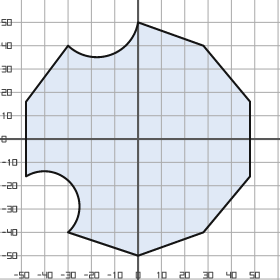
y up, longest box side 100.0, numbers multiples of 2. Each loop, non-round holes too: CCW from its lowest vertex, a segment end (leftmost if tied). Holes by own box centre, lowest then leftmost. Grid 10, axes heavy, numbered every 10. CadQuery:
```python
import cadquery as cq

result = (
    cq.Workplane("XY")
    .moveTo(0.0, -50.0)
    .lineTo(28.0, -40.0)
    .lineTo(48.0, -16.0)
    .lineTo(48.0, 16.0)
    .lineTo(28.0, 40.0)
    .lineTo(0.0, 50.0)
    .threePointArc((-12.0, 36.0), (-30.0, 40.0))
    .lineTo(-48.0, 16.0)
    .lineTo(-48.0, -16.0)
    .threePointArc((-28.0, -20.0), (-30.0, -40.0))
    .close()
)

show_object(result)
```